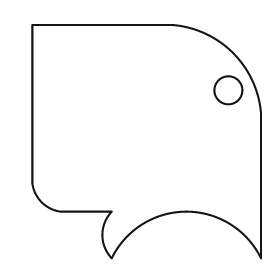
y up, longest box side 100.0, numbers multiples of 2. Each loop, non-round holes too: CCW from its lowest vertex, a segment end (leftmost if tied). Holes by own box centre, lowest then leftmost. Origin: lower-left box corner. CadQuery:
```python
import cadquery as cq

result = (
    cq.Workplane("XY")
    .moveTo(34.0, 0.0)
    .threePointArc((66.0, 20.0), (98.0, 0.0))
    .lineTo(98.0, 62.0)
    .threePointArc((86.0, 88.0), (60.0, 100.0))
    .lineTo(0.0, 100.0)
    .lineTo(0.0, 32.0)
    .threePointArc((4.0, 24.0), (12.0, 20.0))
    .lineTo(34.0, 20.0)
    .threePointArc((30.0, 10.0), (34.0, 0.0))
    .close()
    .moveTo(84.0, 72.0)
    .circle(6.0)
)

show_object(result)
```